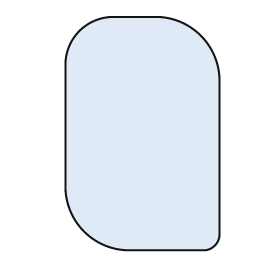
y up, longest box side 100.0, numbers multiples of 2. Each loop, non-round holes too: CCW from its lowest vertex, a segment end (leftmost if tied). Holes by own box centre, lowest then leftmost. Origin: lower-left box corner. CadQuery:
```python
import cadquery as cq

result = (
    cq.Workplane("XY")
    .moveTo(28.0, 0.0)
    .lineTo(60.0, 0.0)
    .threePointArc((64.0, 2.0), (66.0, 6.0))
    .lineTo(66.0, 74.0)
    .threePointArc((58.0, 92.0), (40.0, 100.0))
    .lineTo(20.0, 100.0)
    .threePointArc((6.0, 94.0), (0.0, 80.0))
    .lineTo(0.0, 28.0)
    .threePointArc((8.0, 8.0), (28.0, 0.0))
    .close()
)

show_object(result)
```